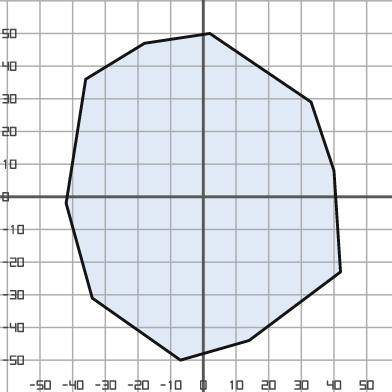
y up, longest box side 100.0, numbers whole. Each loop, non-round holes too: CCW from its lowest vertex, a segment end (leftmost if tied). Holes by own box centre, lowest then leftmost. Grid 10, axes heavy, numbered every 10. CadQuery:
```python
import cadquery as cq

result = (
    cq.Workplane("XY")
    .moveTo(-7.0, -50.0)
    .lineTo(14.0, -44.0)
    .lineTo(42.0, -23.0)
    .lineTo(40.0, 8.0)
    .lineTo(33.0, 29.0)
    .lineTo(2.0, 50.0)
    .lineTo(-18.0, 47.0)
    .lineTo(-36.0, 36.0)
    .lineTo(-42.0, -2.0)
    .lineTo(-34.0, -31.0)
    .close()
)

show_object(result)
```